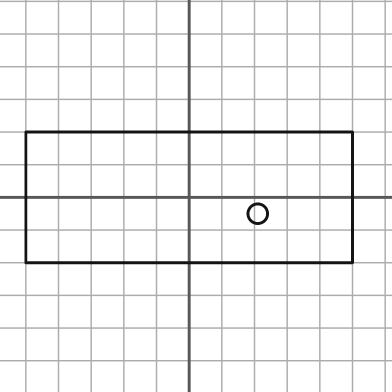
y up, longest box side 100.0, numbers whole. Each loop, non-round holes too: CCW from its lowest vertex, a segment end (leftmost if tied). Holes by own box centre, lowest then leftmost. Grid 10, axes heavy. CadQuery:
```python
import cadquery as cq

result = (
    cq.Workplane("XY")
    .moveTo(-50.0, -20.0)
    .lineTo(50.0, -20.0)
    .lineTo(50.0, 20.0)
    .lineTo(-50.0, 20.0)
    .close()
    .moveTo(21.0, -5.0)
    .circle(3.0)
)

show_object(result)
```